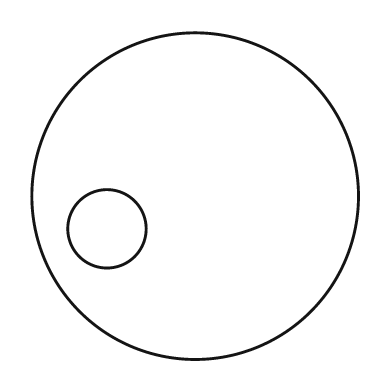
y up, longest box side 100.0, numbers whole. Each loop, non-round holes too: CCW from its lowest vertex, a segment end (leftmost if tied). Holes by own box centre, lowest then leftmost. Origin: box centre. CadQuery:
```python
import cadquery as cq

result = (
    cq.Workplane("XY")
    .moveTo(0.0, 0.0)
    .circle(50.0)
    .moveTo(-27.0, -10.0)
    .circle(12.0)
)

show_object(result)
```